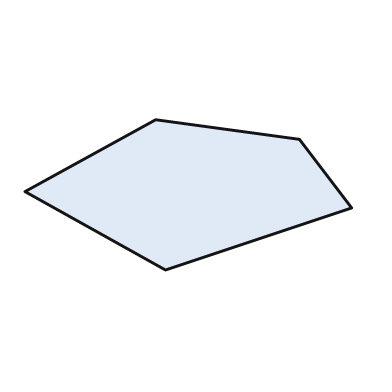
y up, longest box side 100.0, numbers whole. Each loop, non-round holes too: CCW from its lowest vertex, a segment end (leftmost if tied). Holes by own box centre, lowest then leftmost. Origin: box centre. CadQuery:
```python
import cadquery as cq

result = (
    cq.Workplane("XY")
    .moveTo(-7.0, -23.0)
    .lineTo(50.0, -4.0)
    .lineTo(34.0, 17.0)
    .lineTo(-10.0, 23.0)
    .lineTo(-50.0, 1.0)
    .close()
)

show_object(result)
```